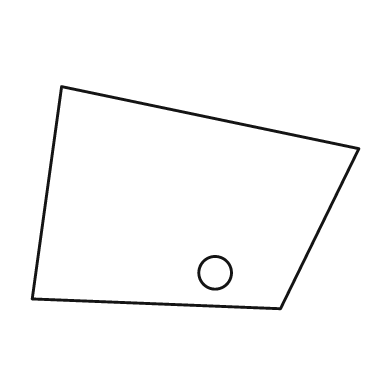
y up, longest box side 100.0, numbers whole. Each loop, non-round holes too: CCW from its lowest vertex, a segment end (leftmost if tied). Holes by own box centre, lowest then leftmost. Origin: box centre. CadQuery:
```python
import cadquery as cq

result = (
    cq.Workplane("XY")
    .moveTo(26.0, -34.0)
    .lineTo(50.0, 15.0)
    .lineTo(-41.0, 34.0)
    .lineTo(-50.0, -31.0)
    .close()
    .moveTo(6.0, -23.0)
    .circle(5.0)
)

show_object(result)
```